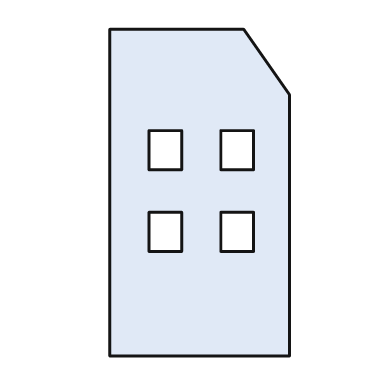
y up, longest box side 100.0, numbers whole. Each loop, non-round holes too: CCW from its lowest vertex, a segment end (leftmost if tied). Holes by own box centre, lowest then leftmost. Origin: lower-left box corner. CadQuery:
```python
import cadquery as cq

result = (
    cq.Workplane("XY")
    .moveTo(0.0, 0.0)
    .lineTo(55.0, 0.0)
    .lineTo(55.0, 80.0)
    .lineTo(41.0, 100.0)
    .lineTo(0.0, 100.0)
    .close()
    .moveTo(12.0, 32.0)
    .lineTo(22.0, 32.0)
    .lineTo(22.0, 44.0)
    .lineTo(12.0, 44.0)
    .close()
    .moveTo(34.0, 32.0)
    .lineTo(44.0, 32.0)
    .lineTo(44.0, 44.0)
    .lineTo(34.0, 44.0)
    .close()
    .moveTo(12.0, 57.0)
    .lineTo(22.0, 57.0)
    .lineTo(22.0, 69.0)
    .lineTo(12.0, 69.0)
    .close()
    .moveTo(34.0, 57.0)
    .lineTo(44.0, 57.0)
    .lineTo(44.0, 69.0)
    .lineTo(34.0, 69.0)
    .close()
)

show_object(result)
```